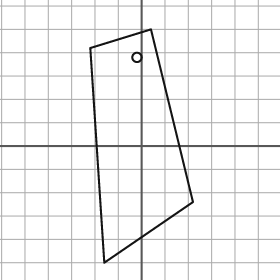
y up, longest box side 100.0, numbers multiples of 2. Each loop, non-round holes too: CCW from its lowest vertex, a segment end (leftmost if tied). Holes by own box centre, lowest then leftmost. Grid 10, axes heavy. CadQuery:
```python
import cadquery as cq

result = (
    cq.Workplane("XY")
    .moveTo(-16.0, -50.0)
    .lineTo(22.0, -24.0)
    .lineTo(4.0, 50.0)
    .lineTo(-22.0, 42.0)
    .close()
    .moveTo(-2.0, 38.0)
    .circle(2.0)
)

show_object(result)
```